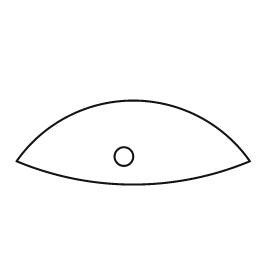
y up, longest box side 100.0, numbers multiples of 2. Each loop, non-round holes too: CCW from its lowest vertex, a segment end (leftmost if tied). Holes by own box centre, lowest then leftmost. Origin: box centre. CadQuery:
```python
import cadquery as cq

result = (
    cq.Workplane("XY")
    .moveTo(-50.0, -8.0)
    .threePointArc((0.0, -18.0), (50.0, -8.0))
    .threePointArc((0.0, 18.0), (-50.0, -8.0))
    .close()
    .moveTo(-4.0, -6.0)
    .circle(4.0)
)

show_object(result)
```